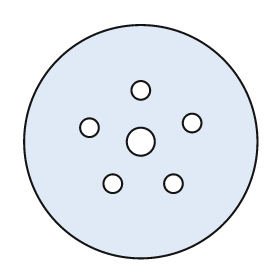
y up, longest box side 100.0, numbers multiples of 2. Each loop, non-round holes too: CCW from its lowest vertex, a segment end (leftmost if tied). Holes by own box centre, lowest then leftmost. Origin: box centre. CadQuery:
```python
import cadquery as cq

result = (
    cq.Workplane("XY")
    .moveTo(0.0, 0.0)
    .circle(50.0)
    .moveTo(-12.0, -18.0)
    .circle(4.0)
    .moveTo(14.0, -18.0)
    .circle(4.0)
    .moveTo(0.0, 0.0)
    .circle(6.0)
    .moveTo(-22.0, 6.0)
    .circle(4.0)
    .moveTo(22.0, 8.0)
    .circle(4.0)
    .moveTo(0.0, 22.0)
    .circle(4.0)
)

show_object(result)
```